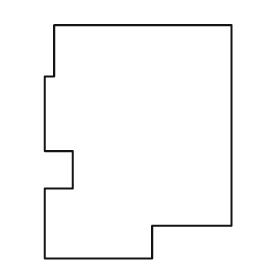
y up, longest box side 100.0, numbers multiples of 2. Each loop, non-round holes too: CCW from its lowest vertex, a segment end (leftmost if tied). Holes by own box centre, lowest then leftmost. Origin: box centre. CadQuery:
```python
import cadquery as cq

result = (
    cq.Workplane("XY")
    .moveTo(-40.0, -50.0)
    .lineTo(6.0, -50.0)
    .lineTo(6.0, -36.0)
    .lineTo(40.0, -36.0)
    .lineTo(40.0, 50.0)
    .lineTo(-36.0, 50.0)
    .lineTo(-36.0, 28.0)
    .lineTo(-40.0, 28.0)
    .lineTo(-40.0, -4.0)
    .lineTo(-28.0, -4.0)
    .lineTo(-28.0, -20.0)
    .lineTo(-40.0, -20.0)
    .close()
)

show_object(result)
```